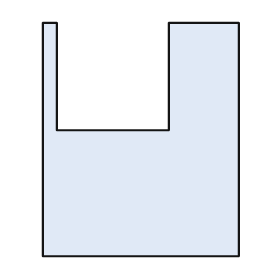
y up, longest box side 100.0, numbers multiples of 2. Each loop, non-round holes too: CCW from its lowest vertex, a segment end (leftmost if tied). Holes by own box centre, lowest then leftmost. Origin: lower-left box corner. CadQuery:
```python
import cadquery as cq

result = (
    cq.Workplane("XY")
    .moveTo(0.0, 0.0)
    .lineTo(84.0, 0.0)
    .lineTo(84.0, 100.0)
    .lineTo(54.0, 100.0)
    .lineTo(54.0, 54.0)
    .lineTo(6.0, 54.0)
    .lineTo(6.0, 100.0)
    .lineTo(0.0, 100.0)
    .close()
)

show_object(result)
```